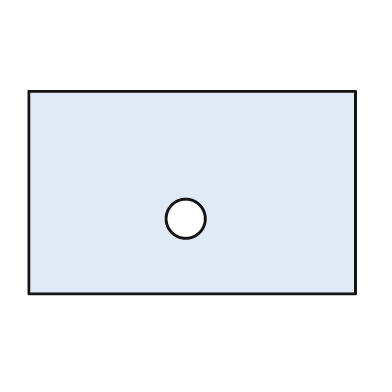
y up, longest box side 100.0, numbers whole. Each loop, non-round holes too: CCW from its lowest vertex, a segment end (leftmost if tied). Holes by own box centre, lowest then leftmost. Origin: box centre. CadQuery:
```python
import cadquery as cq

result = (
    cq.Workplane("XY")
    .moveTo(-50.0, -31.0)
    .lineTo(50.0, -31.0)
    .lineTo(50.0, 31.0)
    .lineTo(-50.0, 31.0)
    .close()
    .moveTo(-2.0, -8.0)
    .circle(6.0)
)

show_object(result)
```